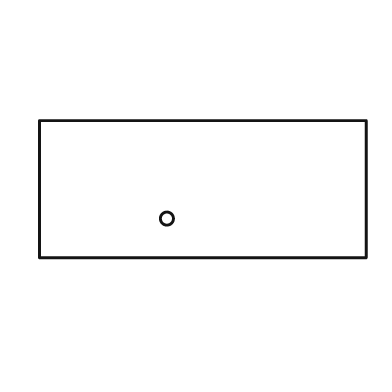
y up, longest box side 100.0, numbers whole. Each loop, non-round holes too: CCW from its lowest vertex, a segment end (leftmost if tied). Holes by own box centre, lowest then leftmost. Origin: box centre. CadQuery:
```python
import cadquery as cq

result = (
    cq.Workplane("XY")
    .moveTo(-50.0, -21.0)
    .lineTo(50.0, -21.0)
    .lineTo(50.0, 21.0)
    .lineTo(-50.0, 21.0)
    .close()
    .moveTo(-11.0, -9.0)
    .circle(2.0)
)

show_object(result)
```